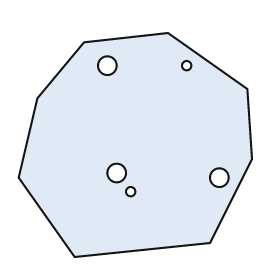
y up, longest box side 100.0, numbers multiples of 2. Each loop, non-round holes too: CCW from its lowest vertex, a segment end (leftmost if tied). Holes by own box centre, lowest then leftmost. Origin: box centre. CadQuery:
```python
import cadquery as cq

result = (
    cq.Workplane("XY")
    .moveTo(-26.0, -48.0)
    .lineTo(32.0, -42.0)
    .lineTo(50.0, -6.0)
    .lineTo(48.0, 24.0)
    .lineTo(14.0, 48.0)
    .lineTo(-22.0, 44.0)
    .lineTo(-42.0, 20.0)
    .lineTo(-50.0, -14.0)
    .close()
    .moveTo(-2.0, -20.0)
    .circle(2.0)
    .moveTo(36.0, -14.0)
    .circle(4.0)
    .moveTo(-8.0, -12.0)
    .circle(4.0)
    .moveTo(-12.0, 34.0)
    .circle(4.0)
    .moveTo(22.0, 34.0)
    .circle(2.0)
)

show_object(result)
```